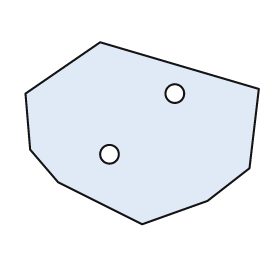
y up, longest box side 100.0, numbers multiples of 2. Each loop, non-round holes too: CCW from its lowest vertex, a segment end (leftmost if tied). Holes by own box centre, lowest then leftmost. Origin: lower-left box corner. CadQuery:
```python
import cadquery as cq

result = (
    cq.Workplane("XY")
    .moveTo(50.0, 0.0)
    .lineTo(78.0, 10.0)
    .lineTo(96.0, 24.0)
    .lineTo(100.0, 58.0)
    .lineTo(32.0, 78.0)
    .lineTo(0.0, 56.0)
    .lineTo(2.0, 32.0)
    .lineTo(14.0, 18.0)
    .close()
    .moveTo(36.0, 30.0)
    .circle(4.0)
    .moveTo(64.0, 56.0)
    .circle(4.0)
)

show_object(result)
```